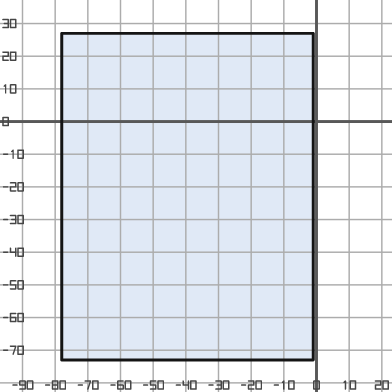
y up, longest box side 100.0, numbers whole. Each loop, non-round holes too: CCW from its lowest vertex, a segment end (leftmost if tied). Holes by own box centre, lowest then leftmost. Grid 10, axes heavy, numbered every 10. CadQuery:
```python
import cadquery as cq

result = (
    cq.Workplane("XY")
    .moveTo(-78.0, -73.0)
    .lineTo(-1.0, -73.0)
    .lineTo(-1.0, 27.0)
    .lineTo(-78.0, 27.0)
    .close()
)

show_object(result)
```